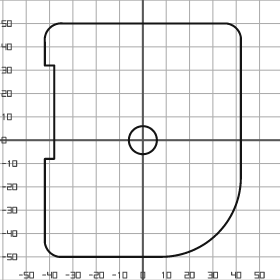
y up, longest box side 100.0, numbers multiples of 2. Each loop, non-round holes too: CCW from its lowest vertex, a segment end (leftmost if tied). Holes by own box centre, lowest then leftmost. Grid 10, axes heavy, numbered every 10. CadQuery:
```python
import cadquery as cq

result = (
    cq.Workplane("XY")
    .moveTo(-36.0, -50.0)
    .lineTo(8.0, -50.0)
    .threePointArc((32.0, -40.0), (42.0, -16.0))
    .lineTo(42.0, 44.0)
    .threePointArc((40.0, 48.0), (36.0, 50.0))
    .lineTo(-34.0, 50.0)
    .threePointArc((-40.0, 48.0), (-42.0, 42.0))
    .lineTo(-42.0, 32.0)
    .lineTo(-38.0, 32.0)
    .lineTo(-38.0, -8.0)
    .lineTo(-42.0, -8.0)
    .lineTo(-42.0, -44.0)
    .threePointArc((-40.0, -48.0), (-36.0, -50.0))
    .close()
    .moveTo(0.0, 0.0)
    .circle(6.0)
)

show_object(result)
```